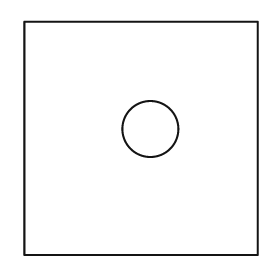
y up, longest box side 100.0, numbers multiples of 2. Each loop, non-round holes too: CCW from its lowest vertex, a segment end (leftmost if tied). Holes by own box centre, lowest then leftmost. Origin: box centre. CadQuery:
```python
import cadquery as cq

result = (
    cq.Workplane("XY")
    .moveTo(-50.0, -50.0)
    .lineTo(50.0, -50.0)
    .lineTo(50.0, 50.0)
    .lineTo(-50.0, 50.0)
    .close()
    .moveTo(4.0, 4.0)
    .circle(12.0)
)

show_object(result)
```